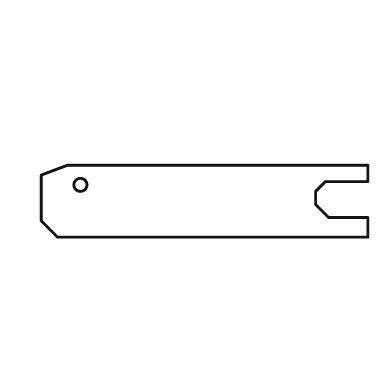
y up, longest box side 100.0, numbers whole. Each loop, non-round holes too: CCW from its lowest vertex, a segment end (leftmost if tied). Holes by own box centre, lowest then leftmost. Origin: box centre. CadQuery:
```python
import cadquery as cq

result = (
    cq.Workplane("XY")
    .moveTo(-45.0, -11.0)
    .lineTo(50.0, -11.0)
    .lineTo(50.0, -5.0)
    .lineTo(38.0, -5.0)
    .lineTo(34.0, -1.0)
    .lineTo(34.0, 3.0)
    .lineTo(37.0, 6.0)
    .lineTo(50.0, 6.0)
    .lineTo(50.0, 11.0)
    .lineTo(-42.0, 11.0)
    .lineTo(-50.0, 8.0)
    .lineTo(-50.0, -6.0)
    .close()
    .moveTo(-38.0, 5.0)
    .circle(2.0)
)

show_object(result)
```